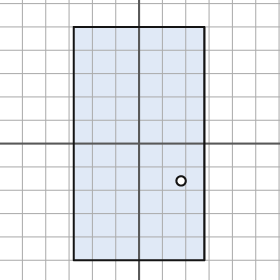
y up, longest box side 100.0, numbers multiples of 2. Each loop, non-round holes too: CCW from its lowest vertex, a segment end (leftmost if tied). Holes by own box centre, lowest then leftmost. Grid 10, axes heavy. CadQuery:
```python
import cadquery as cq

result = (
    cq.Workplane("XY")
    .moveTo(-28.0, -50.0)
    .lineTo(28.0, -50.0)
    .lineTo(28.0, 50.0)
    .lineTo(-28.0, 50.0)
    .close()
    .moveTo(18.0, -16.0)
    .circle(2.0)
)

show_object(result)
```